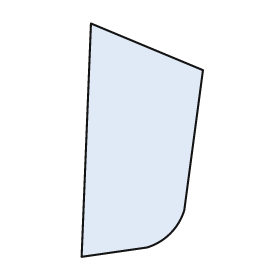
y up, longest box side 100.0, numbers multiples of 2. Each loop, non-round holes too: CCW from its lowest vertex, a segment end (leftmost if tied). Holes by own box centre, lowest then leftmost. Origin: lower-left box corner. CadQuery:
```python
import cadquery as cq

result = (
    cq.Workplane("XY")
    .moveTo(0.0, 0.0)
    .lineTo(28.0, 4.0)
    .threePointArc((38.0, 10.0), (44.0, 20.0))
    .lineTo(52.0, 80.0)
    .lineTo(4.0, 100.0)
    .close()
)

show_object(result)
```